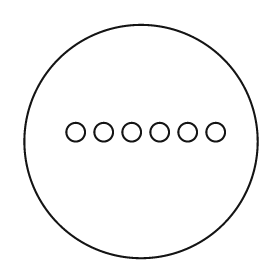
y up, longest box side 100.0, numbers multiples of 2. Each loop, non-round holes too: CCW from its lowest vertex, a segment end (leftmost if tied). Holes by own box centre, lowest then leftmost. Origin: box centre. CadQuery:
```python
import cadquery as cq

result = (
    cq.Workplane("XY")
    .moveTo(0.0, 0.0)
    .circle(50.0)
    .moveTo(-28.0, 4.0)
    .circle(4.0)
    .moveTo(-16.0, 4.0)
    .circle(4.0)
    .moveTo(-4.0, 4.0)
    .circle(4.0)
    .moveTo(8.0, 4.0)
    .circle(4.0)
    .moveTo(20.0, 4.0)
    .circle(4.0)
    .moveTo(32.0, 4.0)
    .circle(4.0)
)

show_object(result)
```